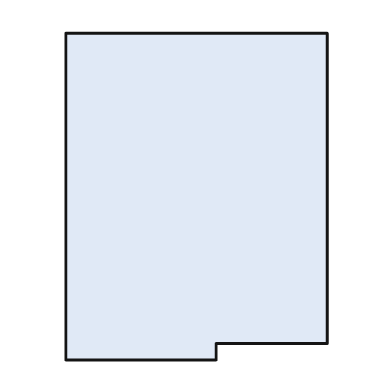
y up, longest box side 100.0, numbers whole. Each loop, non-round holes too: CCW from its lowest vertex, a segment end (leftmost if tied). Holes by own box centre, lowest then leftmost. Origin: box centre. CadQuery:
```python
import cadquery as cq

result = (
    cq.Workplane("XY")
    .moveTo(-40.0, -50.0)
    .lineTo(6.0, -50.0)
    .lineTo(6.0, -45.0)
    .lineTo(40.0, -45.0)
    .lineTo(40.0, 50.0)
    .lineTo(-40.0, 50.0)
    .close()
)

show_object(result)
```